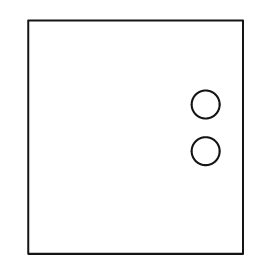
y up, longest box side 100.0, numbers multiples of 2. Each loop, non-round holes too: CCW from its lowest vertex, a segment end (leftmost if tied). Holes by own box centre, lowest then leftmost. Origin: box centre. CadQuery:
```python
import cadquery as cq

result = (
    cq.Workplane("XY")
    .moveTo(-46.0, -50.0)
    .lineTo(46.0, -50.0)
    .lineTo(46.0, 50.0)
    .lineTo(-46.0, 50.0)
    .close()
    .moveTo(30.0, -6.0)
    .circle(6.0)
    .moveTo(30.0, 14.0)
    .circle(6.0)
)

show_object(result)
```